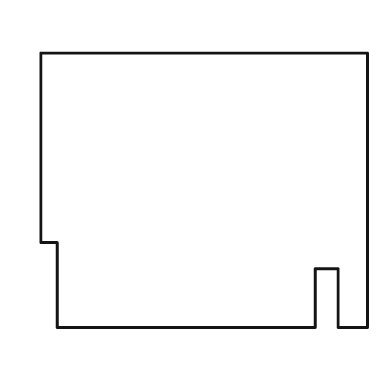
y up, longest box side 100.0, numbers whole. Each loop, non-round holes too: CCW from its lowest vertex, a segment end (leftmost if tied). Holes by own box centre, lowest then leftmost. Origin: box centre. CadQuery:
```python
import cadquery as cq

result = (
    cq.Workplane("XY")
    .moveTo(-45.0, -42.0)
    .lineTo(34.0, -42.0)
    .lineTo(34.0, -24.0)
    .lineTo(41.0, -24.0)
    .lineTo(41.0, -42.0)
    .lineTo(50.0, -42.0)
    .lineTo(50.0, 42.0)
    .lineTo(-50.0, 42.0)
    .lineTo(-50.0, -16.0)
    .lineTo(-45.0, -16.0)
    .close()
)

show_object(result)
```